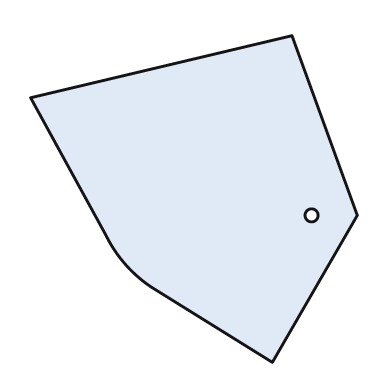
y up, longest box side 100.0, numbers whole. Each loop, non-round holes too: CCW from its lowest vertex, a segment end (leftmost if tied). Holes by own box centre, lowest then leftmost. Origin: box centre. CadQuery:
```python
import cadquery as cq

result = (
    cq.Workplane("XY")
    .moveTo(24.0, -50.0)
    .lineTo(50.0, -5.0)
    .lineTo(30.0, 50.0)
    .lineTo(-50.0, 31.0)
    .lineTo(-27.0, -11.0)
    .threePointArc((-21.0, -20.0), (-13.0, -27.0))
    .close()
    .moveTo(36.0, -5.0)
    .circle(2.0)
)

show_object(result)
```